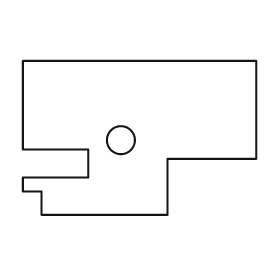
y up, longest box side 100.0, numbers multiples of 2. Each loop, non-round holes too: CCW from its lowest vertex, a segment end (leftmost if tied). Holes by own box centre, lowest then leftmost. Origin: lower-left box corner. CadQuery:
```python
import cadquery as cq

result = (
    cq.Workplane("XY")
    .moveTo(8.0, 0.0)
    .lineTo(62.0, 0.0)
    .lineTo(62.0, 24.0)
    .lineTo(100.0, 24.0)
    .lineTo(100.0, 66.0)
    .lineTo(0.0, 66.0)
    .lineTo(0.0, 28.0)
    .lineTo(28.0, 28.0)
    .lineTo(28.0, 16.0)
    .lineTo(0.0, 16.0)
    .lineTo(0.0, 10.0)
    .lineTo(8.0, 10.0)
    .close()
    .moveTo(42.0, 32.0)
    .circle(6.0)
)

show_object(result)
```